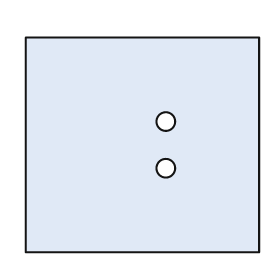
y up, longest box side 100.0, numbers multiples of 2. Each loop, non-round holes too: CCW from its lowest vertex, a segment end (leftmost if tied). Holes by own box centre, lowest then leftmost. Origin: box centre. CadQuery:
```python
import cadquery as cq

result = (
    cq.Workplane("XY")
    .moveTo(-50.0, -46.0)
    .lineTo(50.0, -46.0)
    .lineTo(50.0, 46.0)
    .lineTo(-50.0, 46.0)
    .close()
    .moveTo(10.0, -10.0)
    .circle(4.0)
    .moveTo(10.0, 10.0)
    .circle(4.0)
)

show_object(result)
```